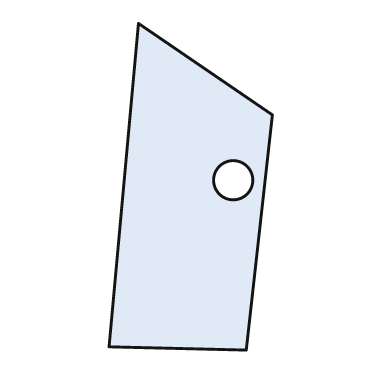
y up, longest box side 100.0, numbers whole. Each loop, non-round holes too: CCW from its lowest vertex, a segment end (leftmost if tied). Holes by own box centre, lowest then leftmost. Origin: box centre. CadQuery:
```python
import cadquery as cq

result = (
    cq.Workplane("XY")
    .moveTo(17.0, -50.0)
    .lineTo(25.0, 22.0)
    .lineTo(-16.0, 50.0)
    .lineTo(-25.0, -49.0)
    .close()
    .moveTo(13.0, 2.0)
    .circle(6.0)
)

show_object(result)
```